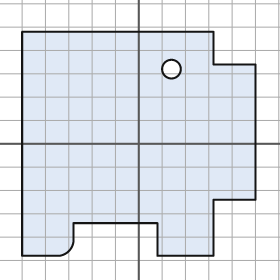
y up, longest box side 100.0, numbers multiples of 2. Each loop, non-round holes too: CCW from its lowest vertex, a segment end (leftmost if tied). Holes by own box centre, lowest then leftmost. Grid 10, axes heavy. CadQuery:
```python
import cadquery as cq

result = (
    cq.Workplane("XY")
    .moveTo(-50.0, -48.0)
    .lineTo(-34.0, -48.0)
    .threePointArc((-30.0, -46.0), (-28.0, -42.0))
    .lineTo(-28.0, -34.0)
    .lineTo(8.0, -34.0)
    .lineTo(8.0, -48.0)
    .lineTo(32.0, -48.0)
    .lineTo(32.0, -24.0)
    .lineTo(50.0, -24.0)
    .lineTo(50.0, 34.0)
    .lineTo(32.0, 34.0)
    .lineTo(32.0, 48.0)
    .lineTo(-50.0, 48.0)
    .close()
    .moveTo(14.0, 32.0)
    .circle(4.0)
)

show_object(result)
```